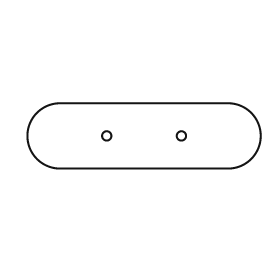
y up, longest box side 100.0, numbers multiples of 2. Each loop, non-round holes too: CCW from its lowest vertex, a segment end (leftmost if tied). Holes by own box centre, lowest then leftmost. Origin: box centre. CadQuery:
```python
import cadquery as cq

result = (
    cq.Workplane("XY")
    .moveTo(-36.0, -14.0)
    .lineTo(36.0, -14.0)
    .threePointArc((50.0, 0.0), (36.0, 14.0))
    .lineTo(-36.0, 14.0)
    .threePointArc((-50.0, 0.0), (-36.0, -14.0))
    .close()
    .moveTo(-16.0, 0.0)
    .circle(2.0)
    .moveTo(16.0, 0.0)
    .circle(2.0)
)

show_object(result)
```